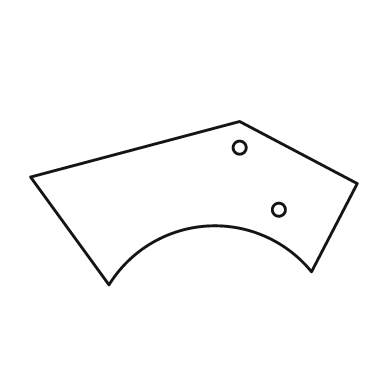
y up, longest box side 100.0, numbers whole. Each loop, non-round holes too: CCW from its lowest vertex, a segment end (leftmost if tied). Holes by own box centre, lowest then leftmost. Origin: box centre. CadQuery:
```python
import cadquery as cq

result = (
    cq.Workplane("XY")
    .moveTo(-26.0, -25.0)
    .threePointArc((4.0, -7.0), (36.0, -21.0))
    .lineTo(50.0, 6.0)
    .lineTo(14.0, 25.0)
    .lineTo(-50.0, 8.0)
    .close()
    .moveTo(26.0, -2.0)
    .circle(2.0)
    .moveTo(14.0, 17.0)
    .circle(2.0)
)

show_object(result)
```